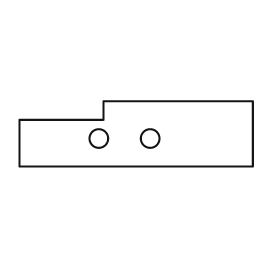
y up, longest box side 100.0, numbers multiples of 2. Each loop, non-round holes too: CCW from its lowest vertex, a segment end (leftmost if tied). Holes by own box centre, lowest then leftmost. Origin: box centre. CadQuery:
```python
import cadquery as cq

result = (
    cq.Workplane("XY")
    .moveTo(-50.0, -14.0)
    .lineTo(50.0, -14.0)
    .lineTo(50.0, 14.0)
    .lineTo(-14.0, 14.0)
    .lineTo(-14.0, 6.0)
    .lineTo(-50.0, 6.0)
    .close()
    .moveTo(-16.0, -2.0)
    .circle(4.0)
    .moveTo(6.0, -2.0)
    .circle(4.0)
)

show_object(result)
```